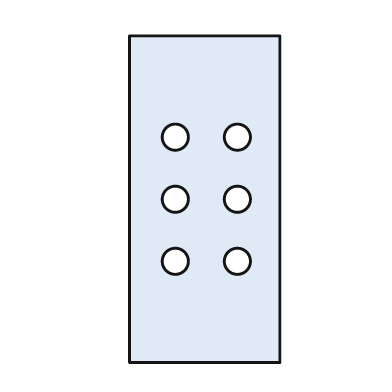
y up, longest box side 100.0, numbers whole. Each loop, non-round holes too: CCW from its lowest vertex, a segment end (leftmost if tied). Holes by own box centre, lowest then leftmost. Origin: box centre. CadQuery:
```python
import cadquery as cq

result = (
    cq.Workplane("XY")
    .moveTo(-23.0, -50.0)
    .lineTo(23.0, -50.0)
    .lineTo(23.0, 50.0)
    .lineTo(-23.0, 50.0)
    .close()
    .moveTo(-9.0, -19.0)
    .circle(4.0)
    .moveTo(10.0, -19.0)
    .circle(4.0)
    .moveTo(-9.0, 0.0)
    .circle(4.0)
    .moveTo(10.0, 0.0)
    .circle(4.0)
    .moveTo(-9.0, 19.0)
    .circle(4.0)
    .moveTo(10.0, 19.0)
    .circle(4.0)
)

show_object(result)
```